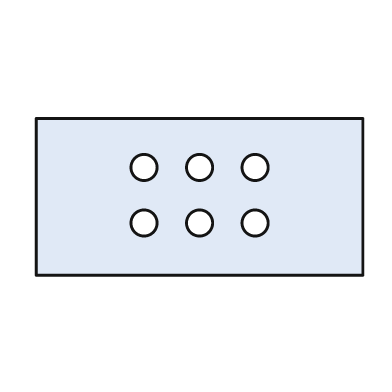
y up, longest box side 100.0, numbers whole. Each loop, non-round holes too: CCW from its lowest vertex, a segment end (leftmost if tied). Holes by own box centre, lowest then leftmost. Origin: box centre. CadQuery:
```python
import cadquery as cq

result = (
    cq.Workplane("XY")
    .moveTo(-50.0, -24.0)
    .lineTo(50.0, -24.0)
    .lineTo(50.0, 24.0)
    .lineTo(-50.0, 24.0)
    .close()
    .moveTo(-17.0, -8.0)
    .circle(4.0)
    .moveTo(0.0, -8.0)
    .circle(4.0)
    .moveTo(17.0, -8.0)
    .circle(4.0)
    .moveTo(-17.0, 9.0)
    .circle(4.0)
    .moveTo(0.0, 9.0)
    .circle(4.0)
    .moveTo(17.0, 9.0)
    .circle(4.0)
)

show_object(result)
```